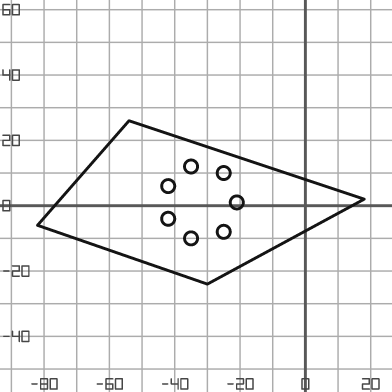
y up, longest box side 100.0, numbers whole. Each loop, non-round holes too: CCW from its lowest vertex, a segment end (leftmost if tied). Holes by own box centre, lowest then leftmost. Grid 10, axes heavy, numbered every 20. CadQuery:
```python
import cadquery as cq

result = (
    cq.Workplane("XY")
    .moveTo(-30.0, -24.0)
    .lineTo(18.0, 2.0)
    .lineTo(-54.0, 26.0)
    .lineTo(-82.0, -6.0)
    .close()
    .moveTo(-35.0, -10.0)
    .circle(2.0)
    .moveTo(-25.0, -8.0)
    .circle(2.0)
    .moveTo(-42.0, -4.0)
    .circle(2.0)
    .moveTo(-21.0, 1.0)
    .circle(2.0)
    .moveTo(-42.0, 6.0)
    .circle(2.0)
    .moveTo(-25.0, 10.0)
    .circle(2.0)
    .moveTo(-35.0, 12.0)
    .circle(2.0)
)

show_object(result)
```